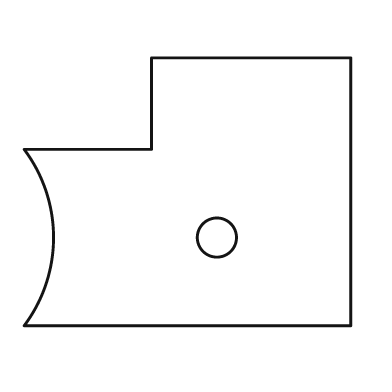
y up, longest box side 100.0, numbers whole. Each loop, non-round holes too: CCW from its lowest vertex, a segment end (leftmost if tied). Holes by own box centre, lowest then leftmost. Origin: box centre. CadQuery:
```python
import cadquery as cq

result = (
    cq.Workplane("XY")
    .moveTo(-50.0, -41.0)
    .lineTo(50.0, -41.0)
    .lineTo(50.0, 41.0)
    .lineTo(-11.0, 41.0)
    .lineTo(-11.0, 13.0)
    .lineTo(-50.0, 13.0)
    .threePointArc((-41.0, -14.0), (-50.0, -41.0))
    .close()
    .moveTo(9.0, -14.0)
    .circle(6.0)
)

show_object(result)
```